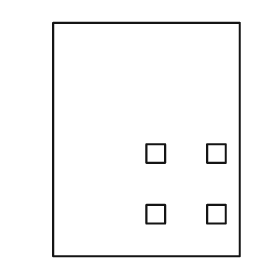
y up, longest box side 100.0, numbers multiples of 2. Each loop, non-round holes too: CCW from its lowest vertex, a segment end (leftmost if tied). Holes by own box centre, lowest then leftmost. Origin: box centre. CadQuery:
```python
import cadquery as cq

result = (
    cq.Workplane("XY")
    .moveTo(-40.0, -50.0)
    .lineTo(40.0, -50.0)
    .lineTo(40.0, 50.0)
    .lineTo(-40.0, 50.0)
    .close()
    .moveTo(0.0, -36.0)
    .lineTo(8.0, -36.0)
    .lineTo(8.0, -28.0)
    .lineTo(0.0, -28.0)
    .close()
    .moveTo(26.0, -36.0)
    .lineTo(34.0, -36.0)
    .lineTo(34.0, -28.0)
    .lineTo(26.0, -28.0)
    .close()
    .moveTo(0.0, -10.0)
    .lineTo(8.0, -10.0)
    .lineTo(8.0, -2.0)
    .lineTo(0.0, -2.0)
    .close()
    .moveTo(26.0, -10.0)
    .lineTo(34.0, -10.0)
    .lineTo(34.0, -2.0)
    .lineTo(26.0, -2.0)
    .close()
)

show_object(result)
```